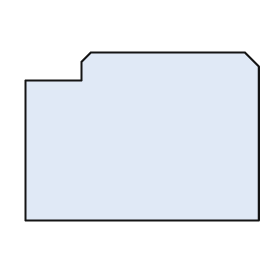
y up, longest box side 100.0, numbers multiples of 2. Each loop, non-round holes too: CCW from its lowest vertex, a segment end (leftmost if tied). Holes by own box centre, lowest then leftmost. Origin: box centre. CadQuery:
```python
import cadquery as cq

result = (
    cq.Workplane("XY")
    .moveTo(-50.0, -36.0)
    .lineTo(50.0, -36.0)
    .lineTo(50.0, 30.0)
    .lineTo(44.0, 36.0)
    .lineTo(-22.0, 36.0)
    .lineTo(-26.0, 32.0)
    .lineTo(-26.0, 24.0)
    .lineTo(-50.0, 24.0)
    .close()
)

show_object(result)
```